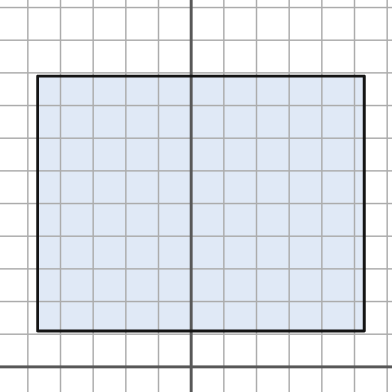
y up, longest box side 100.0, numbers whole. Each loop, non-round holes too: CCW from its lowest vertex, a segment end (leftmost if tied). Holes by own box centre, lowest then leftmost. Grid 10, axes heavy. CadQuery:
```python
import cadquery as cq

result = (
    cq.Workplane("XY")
    .moveTo(-47.0, 11.0)
    .lineTo(53.0, 11.0)
    .lineTo(53.0, 89.0)
    .lineTo(-47.0, 89.0)
    .close()
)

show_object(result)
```